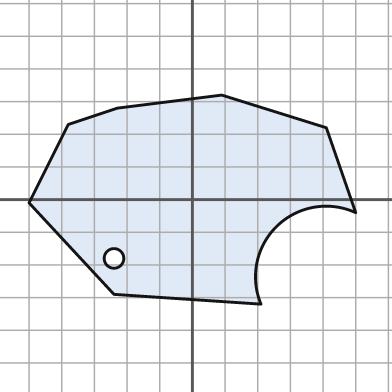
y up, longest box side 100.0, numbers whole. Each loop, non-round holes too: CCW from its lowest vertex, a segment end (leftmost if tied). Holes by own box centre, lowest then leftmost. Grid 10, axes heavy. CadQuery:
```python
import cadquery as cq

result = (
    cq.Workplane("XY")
    .moveTo(21.0, -32.0)
    .threePointArc((26.0, -8.0), (50.0, -4.0))
    .lineTo(41.0, 22.0)
    .lineTo(9.0, 32.0)
    .lineTo(-23.0, 28.0)
    .lineTo(-38.0, 23.0)
    .lineTo(-50.0, -1.0)
    .lineTo(-24.0, -29.0)
    .close()
    .moveTo(-24.0, -18.0)
    .circle(3.0)
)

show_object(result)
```